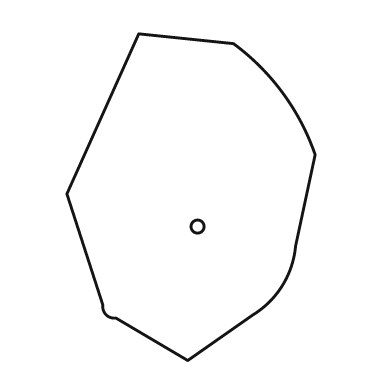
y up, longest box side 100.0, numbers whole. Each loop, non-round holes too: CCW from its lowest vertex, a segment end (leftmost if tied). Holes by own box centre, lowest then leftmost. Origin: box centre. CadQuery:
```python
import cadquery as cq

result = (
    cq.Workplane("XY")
    .moveTo(-1.0, -50.0)
    .lineTo(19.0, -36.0)
    .threePointArc((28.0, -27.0), (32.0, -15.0))
    .lineTo(38.0, 13.0)
    .threePointArc((28.0, 32.0), (13.0, 47.0))
    .lineTo(-16.0, 50.0)
    .lineTo(-38.0, 1.0)
    .lineTo(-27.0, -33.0)
    .threePointArc((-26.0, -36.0), (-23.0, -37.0))
    .close()
    .moveTo(2.0, -9.0)
    .circle(2.0)
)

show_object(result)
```